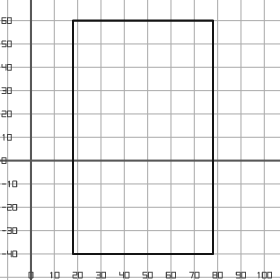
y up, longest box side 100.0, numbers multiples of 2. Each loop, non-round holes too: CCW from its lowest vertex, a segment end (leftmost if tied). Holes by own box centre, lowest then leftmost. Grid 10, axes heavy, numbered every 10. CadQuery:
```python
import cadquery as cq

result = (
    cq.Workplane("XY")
    .moveTo(18.0, -40.0)
    .lineTo(78.0, -40.0)
    .lineTo(78.0, 60.0)
    .lineTo(18.0, 60.0)
    .close()
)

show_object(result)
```